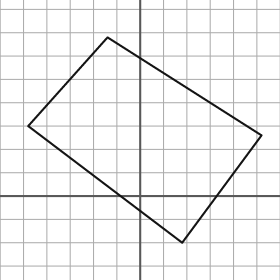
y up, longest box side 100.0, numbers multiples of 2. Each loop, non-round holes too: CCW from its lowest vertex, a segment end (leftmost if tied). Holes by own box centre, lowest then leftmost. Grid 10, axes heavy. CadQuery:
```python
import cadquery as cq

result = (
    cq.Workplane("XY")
    .moveTo(18.0, -20.0)
    .lineTo(52.0, 26.0)
    .lineTo(-14.0, 68.0)
    .lineTo(-48.0, 30.0)
    .close()
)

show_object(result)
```